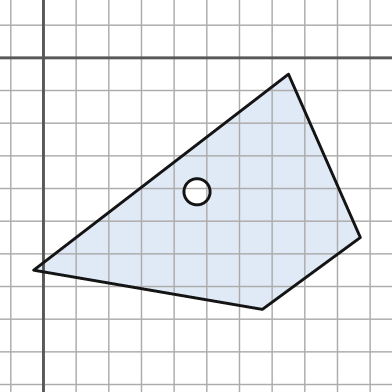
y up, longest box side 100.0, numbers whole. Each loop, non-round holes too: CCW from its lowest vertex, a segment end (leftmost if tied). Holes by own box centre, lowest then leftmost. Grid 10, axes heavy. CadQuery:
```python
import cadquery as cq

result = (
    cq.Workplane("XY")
    .moveTo(67.0, -77.0)
    .lineTo(97.0, -55.0)
    .lineTo(75.0, -5.0)
    .lineTo(-3.0, -65.0)
    .close()
    .moveTo(47.0, -41.0)
    .circle(4.0)
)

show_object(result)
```